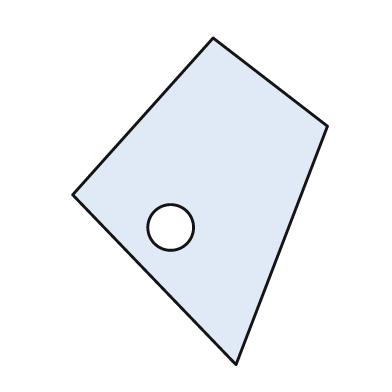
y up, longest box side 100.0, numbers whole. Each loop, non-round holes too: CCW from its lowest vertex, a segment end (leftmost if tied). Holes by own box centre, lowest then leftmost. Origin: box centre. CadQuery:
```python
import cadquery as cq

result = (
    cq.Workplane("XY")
    .moveTo(11.0, -50.0)
    .lineTo(39.0, 23.0)
    .lineTo(4.0, 50.0)
    .lineTo(-39.0, 2.0)
    .close()
    .moveTo(-9.0, -8.0)
    .circle(7.0)
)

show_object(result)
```